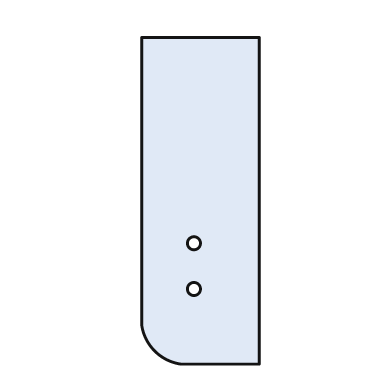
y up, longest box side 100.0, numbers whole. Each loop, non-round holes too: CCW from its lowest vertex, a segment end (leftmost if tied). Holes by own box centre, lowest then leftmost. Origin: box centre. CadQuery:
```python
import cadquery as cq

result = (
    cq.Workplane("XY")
    .moveTo(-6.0, -50.0)
    .lineTo(18.0, -50.0)
    .lineTo(18.0, 50.0)
    .lineTo(-18.0, 50.0)
    .lineTo(-18.0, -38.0)
    .threePointArc((-14.0, -46.0), (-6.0, -50.0))
    .close()
    .moveTo(-2.0, -27.0)
    .circle(2.0)
    .moveTo(-2.0, -13.0)
    .circle(2.0)
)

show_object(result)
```